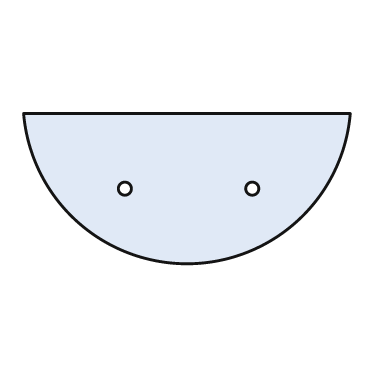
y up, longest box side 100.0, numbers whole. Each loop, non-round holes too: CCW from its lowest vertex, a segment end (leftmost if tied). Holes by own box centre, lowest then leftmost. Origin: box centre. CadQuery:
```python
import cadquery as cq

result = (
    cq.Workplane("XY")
    .moveTo(-50.0, 23.0)
    .threePointArc((0.0, -23.0), (50.0, 23.0))
    .close()
    .moveTo(-19.0, 0.0)
    .circle(2.0)
    .moveTo(20.0, 0.0)
    .circle(2.0)
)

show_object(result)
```